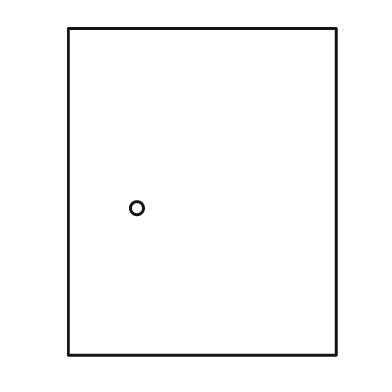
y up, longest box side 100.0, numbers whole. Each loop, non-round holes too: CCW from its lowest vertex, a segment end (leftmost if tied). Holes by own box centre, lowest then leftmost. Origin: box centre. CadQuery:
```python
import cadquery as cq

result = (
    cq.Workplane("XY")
    .moveTo(-41.0, -50.0)
    .lineTo(41.0, -50.0)
    .lineTo(41.0, 50.0)
    .lineTo(-41.0, 50.0)
    .close()
    .moveTo(-20.0, -5.0)
    .circle(2.0)
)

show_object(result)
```